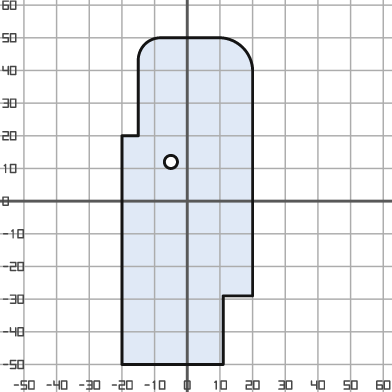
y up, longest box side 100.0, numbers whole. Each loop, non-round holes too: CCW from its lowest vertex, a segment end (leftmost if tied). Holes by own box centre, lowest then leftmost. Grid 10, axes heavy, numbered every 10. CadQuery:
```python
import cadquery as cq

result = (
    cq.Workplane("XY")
    .moveTo(-20.0, -50.0)
    .lineTo(11.0, -50.0)
    .lineTo(11.0, -29.0)
    .lineTo(20.0, -29.0)
    .lineTo(20.0, 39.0)
    .threePointArc((17.0, 47.0), (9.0, 50.0))
    .lineTo(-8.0, 50.0)
    .threePointArc((-13.0, 48.0), (-15.0, 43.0))
    .lineTo(-15.0, 20.0)
    .lineTo(-20.0, 20.0)
    .close()
    .moveTo(-5.0, 12.0)
    .circle(2.0)
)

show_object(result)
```